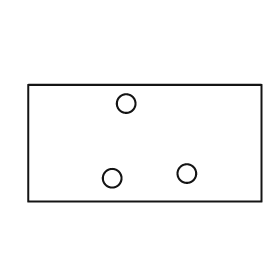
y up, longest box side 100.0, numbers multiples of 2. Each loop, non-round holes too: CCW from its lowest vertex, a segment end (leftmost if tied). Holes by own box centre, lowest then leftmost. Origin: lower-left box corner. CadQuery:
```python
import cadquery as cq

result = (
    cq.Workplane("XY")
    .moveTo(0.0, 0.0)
    .lineTo(100.0, 0.0)
    .lineTo(100.0, 50.0)
    .lineTo(0.0, 50.0)
    .close()
    .moveTo(36.0, 10.0)
    .circle(4.0)
    .moveTo(68.0, 12.0)
    .circle(4.0)
    .moveTo(42.0, 42.0)
    .circle(4.0)
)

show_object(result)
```